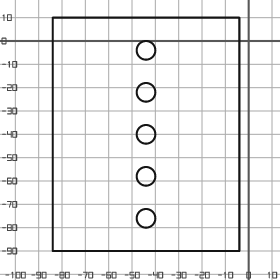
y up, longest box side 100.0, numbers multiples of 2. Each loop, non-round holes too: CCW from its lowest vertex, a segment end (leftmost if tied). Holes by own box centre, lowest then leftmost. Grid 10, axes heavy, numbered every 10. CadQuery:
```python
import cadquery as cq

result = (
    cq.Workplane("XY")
    .moveTo(-84.0, -90.0)
    .lineTo(-4.0, -90.0)
    .lineTo(-4.0, 10.0)
    .lineTo(-84.0, 10.0)
    .close()
    .moveTo(-44.0, -76.0)
    .circle(4.0)
    .moveTo(-44.0, -58.0)
    .circle(4.0)
    .moveTo(-44.0, -40.0)
    .circle(4.0)
    .moveTo(-44.0, -22.0)
    .circle(4.0)
    .moveTo(-44.0, -4.0)
    .circle(4.0)
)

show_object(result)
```